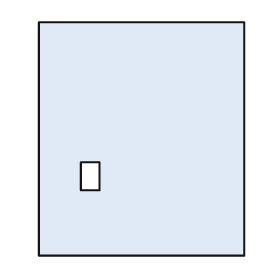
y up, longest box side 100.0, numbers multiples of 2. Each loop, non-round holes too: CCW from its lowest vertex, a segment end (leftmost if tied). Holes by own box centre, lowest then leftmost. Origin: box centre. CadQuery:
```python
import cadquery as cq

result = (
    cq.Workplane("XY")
    .moveTo(-44.0, -50.0)
    .lineTo(44.0, -50.0)
    .lineTo(44.0, 50.0)
    .lineTo(-44.0, 50.0)
    .close()
    .moveTo(-26.0, -22.0)
    .lineTo(-18.0, -22.0)
    .lineTo(-18.0, -10.0)
    .lineTo(-26.0, -10.0)
    .close()
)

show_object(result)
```